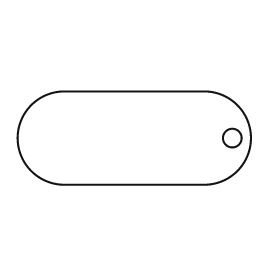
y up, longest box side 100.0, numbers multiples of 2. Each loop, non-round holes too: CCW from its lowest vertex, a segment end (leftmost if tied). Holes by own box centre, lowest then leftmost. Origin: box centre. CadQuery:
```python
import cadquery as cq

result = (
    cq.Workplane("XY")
    .moveTo(-30.0, -20.0)
    .lineTo(30.0, -20.0)
    .threePointArc((50.0, 0.0), (30.0, 20.0))
    .lineTo(-30.0, 20.0)
    .threePointArc((-50.0, 0.0), (-30.0, -20.0))
    .close()
    .moveTo(42.0, 0.0)
    .circle(4.0)
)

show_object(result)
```